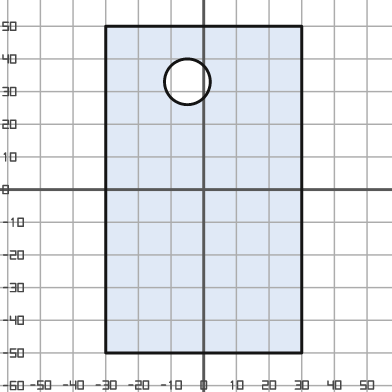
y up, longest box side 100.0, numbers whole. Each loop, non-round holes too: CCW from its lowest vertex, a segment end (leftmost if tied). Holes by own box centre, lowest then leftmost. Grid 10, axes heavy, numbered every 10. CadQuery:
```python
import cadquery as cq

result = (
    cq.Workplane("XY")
    .moveTo(-30.0, -50.0)
    .lineTo(30.0, -50.0)
    .lineTo(30.0, 50.0)
    .lineTo(-30.0, 50.0)
    .close()
    .moveTo(-5.0, 33.0)
    .circle(7.0)
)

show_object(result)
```